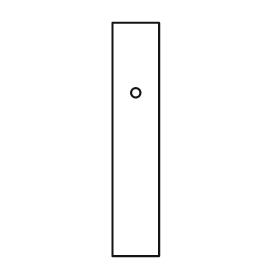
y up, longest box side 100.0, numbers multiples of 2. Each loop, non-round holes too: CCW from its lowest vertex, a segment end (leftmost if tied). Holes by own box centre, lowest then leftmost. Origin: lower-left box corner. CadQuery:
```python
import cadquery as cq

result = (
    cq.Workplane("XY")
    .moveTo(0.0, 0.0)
    .lineTo(20.0, 0.0)
    .lineTo(20.0, 100.0)
    .lineTo(0.0, 100.0)
    .close()
    .moveTo(10.0, 70.0)
    .circle(2.0)
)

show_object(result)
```